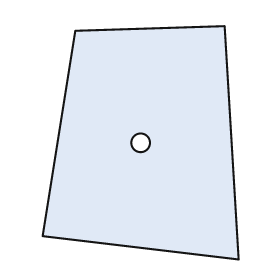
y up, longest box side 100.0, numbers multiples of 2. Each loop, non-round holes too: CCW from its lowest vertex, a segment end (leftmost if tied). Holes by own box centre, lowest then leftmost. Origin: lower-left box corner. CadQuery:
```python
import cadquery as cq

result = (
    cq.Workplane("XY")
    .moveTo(84.0, 0.0)
    .lineTo(78.0, 100.0)
    .lineTo(14.0, 98.0)
    .lineTo(0.0, 10.0)
    .close()
    .moveTo(42.0, 50.0)
    .circle(4.0)
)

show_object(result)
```